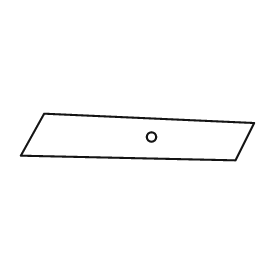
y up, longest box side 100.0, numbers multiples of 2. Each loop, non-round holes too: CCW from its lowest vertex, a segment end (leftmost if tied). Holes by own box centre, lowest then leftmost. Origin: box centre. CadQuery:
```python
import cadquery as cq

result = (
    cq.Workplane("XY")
    .moveTo(42.0, -10.0)
    .lineTo(50.0, 6.0)
    .lineTo(-40.0, 10.0)
    .lineTo(-50.0, -8.0)
    .close()
    .moveTo(6.0, 0.0)
    .circle(2.0)
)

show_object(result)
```